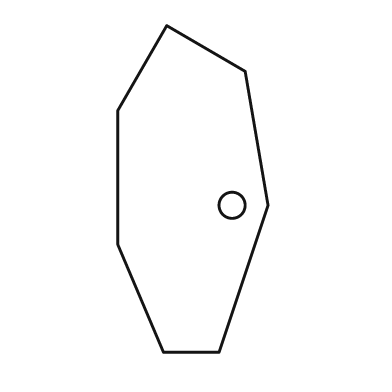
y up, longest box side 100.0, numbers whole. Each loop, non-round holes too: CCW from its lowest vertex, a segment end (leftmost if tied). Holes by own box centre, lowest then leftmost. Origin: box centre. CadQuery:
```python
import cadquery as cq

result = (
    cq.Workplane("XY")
    .moveTo(-9.0, -50.0)
    .lineTo(8.0, -50.0)
    .lineTo(23.0, -5.0)
    .lineTo(16.0, 36.0)
    .lineTo(-8.0, 50.0)
    .lineTo(-23.0, 24.0)
    .lineTo(-23.0, -17.0)
    .close()
    .moveTo(12.0, -5.0)
    .circle(4.0)
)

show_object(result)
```